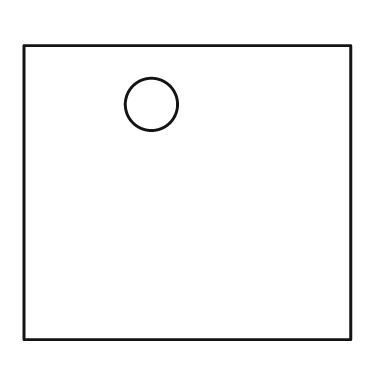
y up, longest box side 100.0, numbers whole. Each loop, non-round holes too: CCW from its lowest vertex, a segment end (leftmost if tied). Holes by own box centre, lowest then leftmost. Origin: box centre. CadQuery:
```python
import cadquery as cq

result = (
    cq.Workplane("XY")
    .moveTo(-50.0, -45.0)
    .lineTo(50.0, -45.0)
    .lineTo(50.0, 45.0)
    .lineTo(-50.0, 45.0)
    .close()
    .moveTo(-11.0, 27.0)
    .circle(8.0)
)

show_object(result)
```